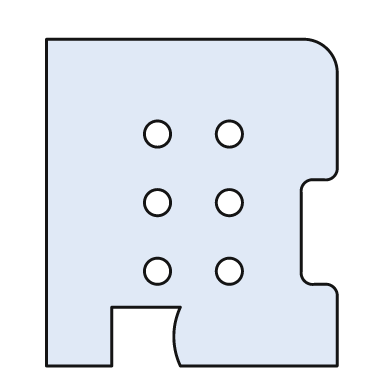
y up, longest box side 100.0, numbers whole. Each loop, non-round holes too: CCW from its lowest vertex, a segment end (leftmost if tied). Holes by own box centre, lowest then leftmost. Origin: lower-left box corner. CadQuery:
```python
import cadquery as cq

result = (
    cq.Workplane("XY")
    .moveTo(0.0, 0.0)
    .lineTo(20.0, 0.0)
    .lineTo(20.0, 18.0)
    .lineTo(41.0, 18.0)
    .threePointArc((39.0, 9.0), (41.0, 0.0))
    .lineTo(89.0, 0.0)
    .lineTo(89.0, 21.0)
    .threePointArc((88.0, 24.0), (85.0, 25.0))
    .lineTo(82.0, 25.0)
    .threePointArc((79.0, 26.0), (78.0, 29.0))
    .lineTo(78.0, 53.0)
    .threePointArc((79.0, 56.0), (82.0, 57.0))
    .lineTo(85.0, 57.0)
    .threePointArc((88.0, 58.0), (89.0, 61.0))
    .lineTo(89.0, 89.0)
    .threePointArc((86.0, 97.0), (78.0, 100.0))
    .lineTo(0.0, 100.0)
    .close()
    .moveTo(34.0, 29.0)
    .circle(4.0)
    .moveTo(56.0, 29.0)
    .circle(4.0)
    .moveTo(34.0, 50.0)
    .circle(4.0)
    .moveTo(56.0, 50.0)
    .circle(4.0)
    .moveTo(34.0, 71.0)
    .circle(4.0)
    .moveTo(56.0, 71.0)
    .circle(4.0)
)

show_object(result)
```